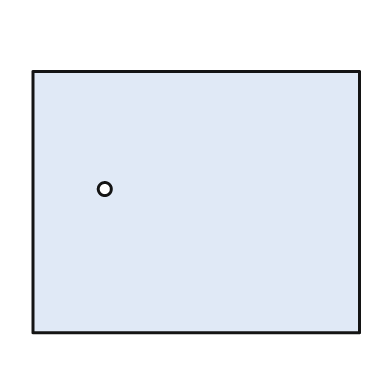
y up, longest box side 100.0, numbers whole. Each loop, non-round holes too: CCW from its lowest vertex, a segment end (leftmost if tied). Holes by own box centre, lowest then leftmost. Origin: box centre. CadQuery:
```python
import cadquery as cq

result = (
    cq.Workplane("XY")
    .moveTo(-50.0, -40.0)
    .lineTo(50.0, -40.0)
    .lineTo(50.0, 40.0)
    .lineTo(-50.0, 40.0)
    .close()
    .moveTo(-28.0, 4.0)
    .circle(2.0)
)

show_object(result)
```